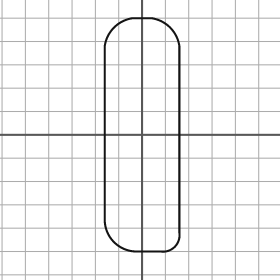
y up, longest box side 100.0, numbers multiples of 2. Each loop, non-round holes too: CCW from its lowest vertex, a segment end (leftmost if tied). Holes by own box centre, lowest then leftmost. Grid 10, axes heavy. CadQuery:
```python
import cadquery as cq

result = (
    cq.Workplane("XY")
    .moveTo(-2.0, -50.0)
    .lineTo(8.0, -50.0)
    .threePointArc((14.0, -48.0), (16.0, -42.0))
    .lineTo(16.0, 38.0)
    .threePointArc((12.0, 46.0), (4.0, 50.0))
    .lineTo(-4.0, 50.0)
    .threePointArc((-12.0, 46.0), (-16.0, 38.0))
    .lineTo(-16.0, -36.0)
    .threePointArc((-12.0, -46.0), (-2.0, -50.0))
    .close()
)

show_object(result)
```